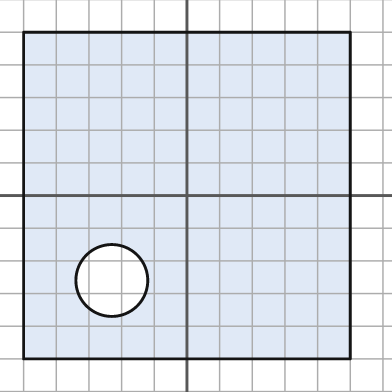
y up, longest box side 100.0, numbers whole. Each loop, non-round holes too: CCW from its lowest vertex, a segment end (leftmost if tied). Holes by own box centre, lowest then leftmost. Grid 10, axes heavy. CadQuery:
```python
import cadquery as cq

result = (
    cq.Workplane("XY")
    .moveTo(-50.0, -50.0)
    .lineTo(50.0, -50.0)
    .lineTo(50.0, 50.0)
    .lineTo(-50.0, 50.0)
    .close()
    .moveTo(-23.0, -26.0)
    .circle(11.0)
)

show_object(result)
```